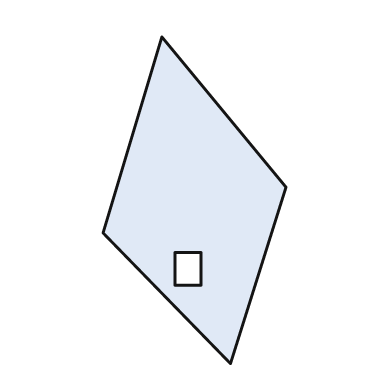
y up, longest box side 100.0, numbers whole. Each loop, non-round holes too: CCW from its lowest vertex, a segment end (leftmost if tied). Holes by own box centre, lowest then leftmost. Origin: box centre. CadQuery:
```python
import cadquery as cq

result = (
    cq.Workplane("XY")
    .moveTo(11.0, -50.0)
    .lineTo(28.0, 4.0)
    .lineTo(-10.0, 50.0)
    .lineTo(-28.0, -10.0)
    .close()
    .moveTo(-6.0, -26.0)
    .lineTo(2.0, -26.0)
    .lineTo(2.0, -16.0)
    .lineTo(-6.0, -16.0)
    .close()
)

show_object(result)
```